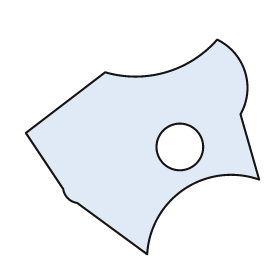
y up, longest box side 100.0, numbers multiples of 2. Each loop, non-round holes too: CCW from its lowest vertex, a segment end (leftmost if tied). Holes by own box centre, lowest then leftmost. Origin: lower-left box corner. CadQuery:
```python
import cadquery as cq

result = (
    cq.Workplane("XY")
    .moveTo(52.0, 0.0)
    .threePointArc((68.0, 28.0), (100.0, 32.0))
    .lineTo(92.0, 60.0)
    .threePointArc((94.0, 78.0), (82.0, 92.0))
    .threePointArc((60.0, 78.0), (34.0, 78.0))
    .lineTo(0.0, 52.0)
    .lineTo(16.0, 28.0)
    .threePointArc((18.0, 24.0), (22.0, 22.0))
    .close()
    .moveTo(66.0, 46.0)
    .circle(10.0)
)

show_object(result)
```